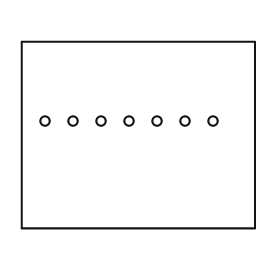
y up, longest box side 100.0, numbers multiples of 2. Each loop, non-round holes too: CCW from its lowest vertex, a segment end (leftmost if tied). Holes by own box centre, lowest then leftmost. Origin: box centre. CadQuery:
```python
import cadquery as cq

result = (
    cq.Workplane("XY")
    .moveTo(-50.0, -40.0)
    .lineTo(50.0, -40.0)
    .lineTo(50.0, 40.0)
    .lineTo(-50.0, 40.0)
    .close()
    .moveTo(-40.0, 6.0)
    .circle(2.0)
    .moveTo(-28.0, 6.0)
    .circle(2.0)
    .moveTo(-16.0, 6.0)
    .circle(2.0)
    .moveTo(-4.0, 6.0)
    .circle(2.0)
    .moveTo(8.0, 6.0)
    .circle(2.0)
    .moveTo(20.0, 6.0)
    .circle(2.0)
    .moveTo(32.0, 6.0)
    .circle(2.0)
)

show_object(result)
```